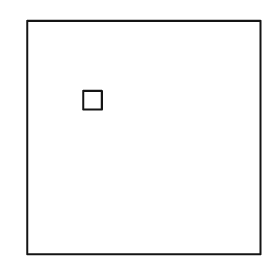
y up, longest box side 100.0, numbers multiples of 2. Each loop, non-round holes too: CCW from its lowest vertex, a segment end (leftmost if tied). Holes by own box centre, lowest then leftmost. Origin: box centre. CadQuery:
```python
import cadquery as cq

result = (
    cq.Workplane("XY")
    .moveTo(-50.0, -50.0)
    .lineTo(50.0, -50.0)
    .lineTo(50.0, 50.0)
    .lineTo(-50.0, 50.0)
    .close()
    .moveTo(-26.0, 12.0)
    .lineTo(-18.0, 12.0)
    .lineTo(-18.0, 20.0)
    .lineTo(-26.0, 20.0)
    .close()
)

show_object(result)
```